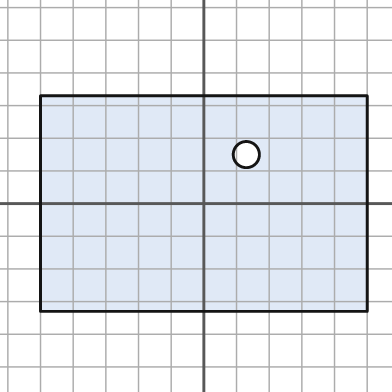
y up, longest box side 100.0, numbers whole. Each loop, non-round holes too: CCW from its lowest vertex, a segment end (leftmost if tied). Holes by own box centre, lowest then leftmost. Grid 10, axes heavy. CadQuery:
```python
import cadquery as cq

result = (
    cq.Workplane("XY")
    .moveTo(-50.0, -33.0)
    .lineTo(50.0, -33.0)
    .lineTo(50.0, 33.0)
    .lineTo(-50.0, 33.0)
    .close()
    .moveTo(13.0, 15.0)
    .circle(4.0)
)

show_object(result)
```